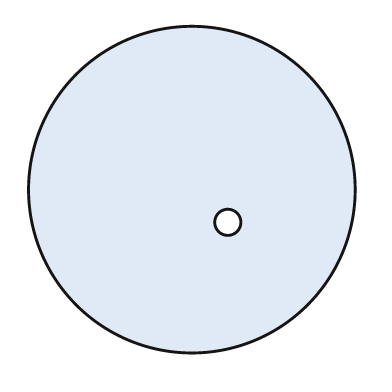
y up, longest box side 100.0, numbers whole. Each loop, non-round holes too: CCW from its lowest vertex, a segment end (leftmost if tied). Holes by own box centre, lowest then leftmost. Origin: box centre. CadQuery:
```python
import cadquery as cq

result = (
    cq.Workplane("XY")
    .moveTo(0.0, 0.0)
    .circle(50.0)
    .moveTo(11.0, -10.0)
    .circle(4.0)
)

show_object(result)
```